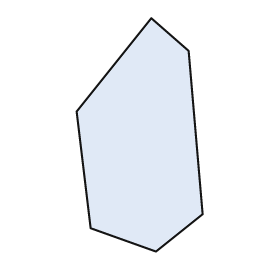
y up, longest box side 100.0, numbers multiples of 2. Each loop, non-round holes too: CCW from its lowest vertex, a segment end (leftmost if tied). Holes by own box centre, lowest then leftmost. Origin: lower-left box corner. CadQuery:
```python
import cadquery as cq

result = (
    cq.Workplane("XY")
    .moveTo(34.0, 0.0)
    .lineTo(54.0, 16.0)
    .lineTo(48.0, 86.0)
    .lineTo(32.0, 100.0)
    .lineTo(0.0, 60.0)
    .lineTo(6.0, 10.0)
    .close()
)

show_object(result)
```